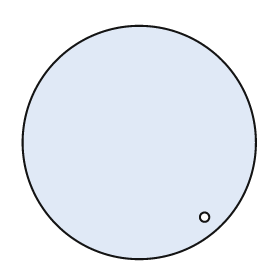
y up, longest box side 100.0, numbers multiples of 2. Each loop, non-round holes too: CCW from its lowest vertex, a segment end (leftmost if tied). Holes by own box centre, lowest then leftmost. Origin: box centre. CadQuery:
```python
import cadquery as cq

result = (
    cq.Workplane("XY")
    .moveTo(0.0, 0.0)
    .circle(50.0)
    .moveTo(28.0, -32.0)
    .circle(2.0)
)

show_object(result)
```